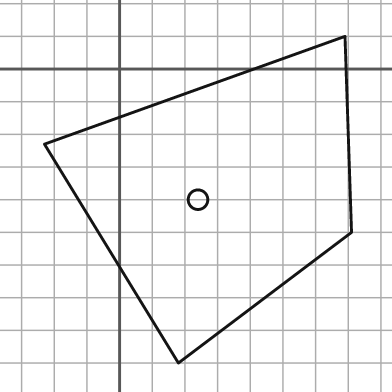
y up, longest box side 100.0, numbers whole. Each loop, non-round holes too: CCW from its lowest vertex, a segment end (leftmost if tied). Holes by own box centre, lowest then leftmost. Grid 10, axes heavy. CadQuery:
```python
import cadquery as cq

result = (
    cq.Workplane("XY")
    .moveTo(18.0, -90.0)
    .lineTo(71.0, -50.0)
    .lineTo(69.0, 10.0)
    .lineTo(-23.0, -23.0)
    .close()
    .moveTo(24.0, -40.0)
    .circle(3.0)
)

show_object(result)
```